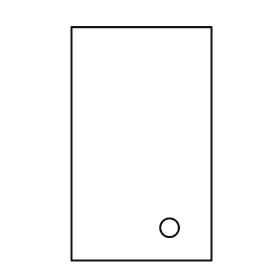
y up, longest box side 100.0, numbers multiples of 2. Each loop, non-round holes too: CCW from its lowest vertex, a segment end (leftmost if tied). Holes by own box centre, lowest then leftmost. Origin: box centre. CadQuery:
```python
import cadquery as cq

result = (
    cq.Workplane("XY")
    .moveTo(-30.0, -50.0)
    .lineTo(30.0, -50.0)
    .lineTo(30.0, 50.0)
    .lineTo(-30.0, 50.0)
    .close()
    .moveTo(12.0, -36.0)
    .circle(4.0)
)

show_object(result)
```